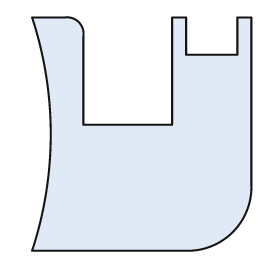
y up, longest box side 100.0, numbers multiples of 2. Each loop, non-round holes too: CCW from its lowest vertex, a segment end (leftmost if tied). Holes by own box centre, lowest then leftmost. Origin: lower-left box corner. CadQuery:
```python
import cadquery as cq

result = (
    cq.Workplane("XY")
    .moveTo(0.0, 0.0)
    .lineTo(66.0, 0.0)
    .threePointArc((86.0, 8.0), (94.0, 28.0))
    .lineTo(94.0, 100.0)
    .lineTo(88.0, 100.0)
    .lineTo(88.0, 84.0)
    .lineTo(66.0, 84.0)
    .lineTo(66.0, 100.0)
    .lineTo(60.0, 100.0)
    .lineTo(60.0, 54.0)
    .lineTo(22.0, 54.0)
    .lineTo(22.0, 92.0)
    .threePointArc((20.0, 98.0), (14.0, 100.0))
    .lineTo(0.0, 100.0)
    .threePointArc((8.0, 50.0), (0.0, 0.0))
    .close()
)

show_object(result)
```